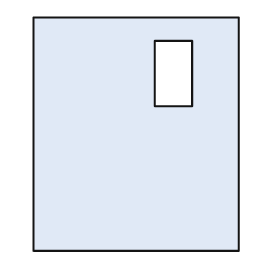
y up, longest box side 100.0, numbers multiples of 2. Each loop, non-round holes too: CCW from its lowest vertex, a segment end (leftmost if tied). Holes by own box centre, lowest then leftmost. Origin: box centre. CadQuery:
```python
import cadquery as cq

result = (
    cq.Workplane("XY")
    .moveTo(-44.0, -50.0)
    .lineTo(44.0, -50.0)
    .lineTo(44.0, 50.0)
    .lineTo(-44.0, 50.0)
    .close()
    .moveTo(8.0, 12.0)
    .lineTo(24.0, 12.0)
    .lineTo(24.0, 40.0)
    .lineTo(8.0, 40.0)
    .close()
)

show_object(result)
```